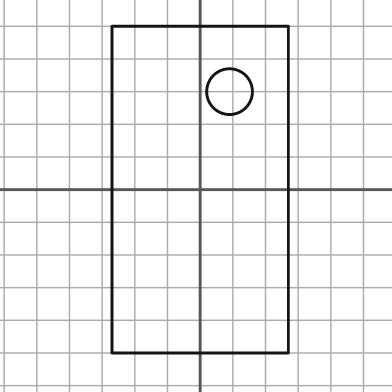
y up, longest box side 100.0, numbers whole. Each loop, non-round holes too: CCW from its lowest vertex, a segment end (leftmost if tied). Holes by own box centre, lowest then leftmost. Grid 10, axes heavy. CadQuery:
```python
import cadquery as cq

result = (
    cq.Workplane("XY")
    .moveTo(-27.0, -50.0)
    .lineTo(27.0, -50.0)
    .lineTo(27.0, 50.0)
    .lineTo(-27.0, 50.0)
    .close()
    .moveTo(9.0, 30.0)
    .circle(7.0)
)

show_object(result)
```